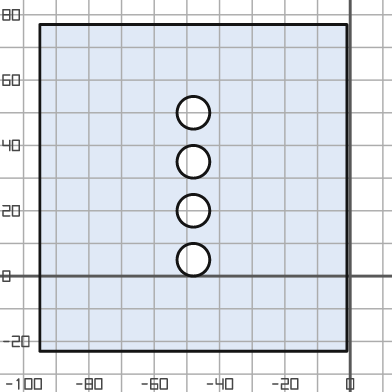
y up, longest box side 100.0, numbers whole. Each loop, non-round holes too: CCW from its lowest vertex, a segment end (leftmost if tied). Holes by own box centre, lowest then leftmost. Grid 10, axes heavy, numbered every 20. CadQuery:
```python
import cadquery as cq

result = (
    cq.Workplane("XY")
    .moveTo(-95.0, -23.0)
    .lineTo(-1.0, -23.0)
    .lineTo(-1.0, 77.0)
    .lineTo(-95.0, 77.0)
    .close()
    .moveTo(-48.0, 5.0)
    .circle(5.0)
    .moveTo(-48.0, 20.0)
    .circle(5.0)
    .moveTo(-48.0, 35.0)
    .circle(5.0)
    .moveTo(-48.0, 50.0)
    .circle(5.0)
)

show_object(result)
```